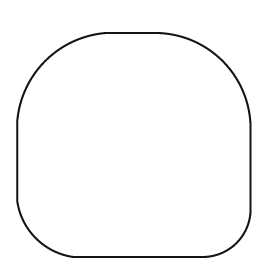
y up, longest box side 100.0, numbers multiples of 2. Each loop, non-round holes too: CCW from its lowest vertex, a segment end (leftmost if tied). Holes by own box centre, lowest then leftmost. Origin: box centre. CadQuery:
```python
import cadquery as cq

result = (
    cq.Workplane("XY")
    .moveTo(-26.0, -48.0)
    .lineTo(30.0, -48.0)
    .threePointArc((44.0, -42.0), (50.0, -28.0))
    .lineTo(50.0, 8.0)
    .threePointArc((38.0, 36.0), (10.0, 48.0))
    .lineTo(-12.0, 48.0)
    .threePointArc((-38.0, 36.0), (-50.0, 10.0))
    .lineTo(-50.0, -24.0)
    .threePointArc((-42.0, -40.0), (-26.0, -48.0))
    .close()
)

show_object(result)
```